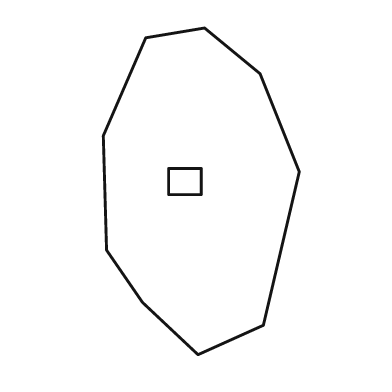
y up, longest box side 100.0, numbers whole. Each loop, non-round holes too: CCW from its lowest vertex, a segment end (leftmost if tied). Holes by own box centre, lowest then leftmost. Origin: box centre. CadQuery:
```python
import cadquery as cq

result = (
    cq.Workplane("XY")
    .moveTo(-1.0, -50.0)
    .lineTo(19.0, -41.0)
    .lineTo(30.0, 6.0)
    .lineTo(18.0, 36.0)
    .lineTo(1.0, 50.0)
    .lineTo(-17.0, 47.0)
    .lineTo(-30.0, 17.0)
    .lineTo(-29.0, -18.0)
    .lineTo(-18.0, -34.0)
    .close()
    .moveTo(-10.0, -1.0)
    .lineTo(0.0, -1.0)
    .lineTo(0.0, 7.0)
    .lineTo(-10.0, 7.0)
    .close()
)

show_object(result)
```